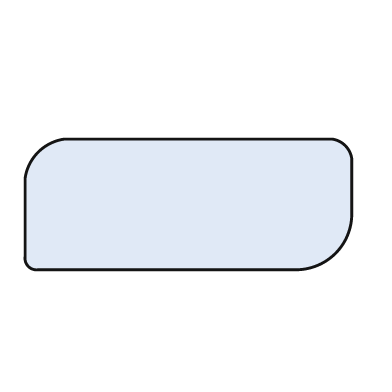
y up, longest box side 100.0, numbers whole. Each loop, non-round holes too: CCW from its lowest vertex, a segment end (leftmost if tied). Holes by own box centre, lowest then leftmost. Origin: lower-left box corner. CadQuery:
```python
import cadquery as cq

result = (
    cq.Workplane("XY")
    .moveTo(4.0, 0.0)
    .lineTo(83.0, 0.0)
    .threePointArc((95.0, 5.0), (100.0, 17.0))
    .lineTo(100.0, 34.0)
    .threePointArc((98.0, 38.0), (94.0, 40.0))
    .lineTo(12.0, 40.0)
    .threePointArc((4.0, 36.0), (0.0, 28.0))
    .lineTo(0.0, 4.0)
    .threePointArc((1.0, 1.0), (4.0, 0.0))
    .close()
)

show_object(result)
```